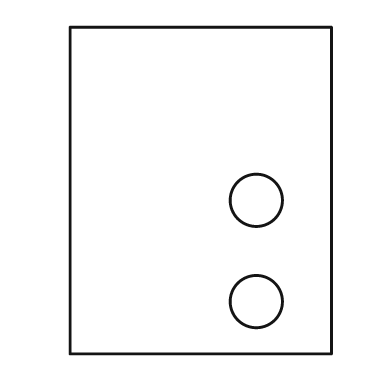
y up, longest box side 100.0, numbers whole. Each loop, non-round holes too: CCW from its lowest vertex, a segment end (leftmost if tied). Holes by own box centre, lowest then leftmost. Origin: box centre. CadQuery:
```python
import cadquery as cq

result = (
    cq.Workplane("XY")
    .moveTo(-40.0, -50.0)
    .lineTo(40.0, -50.0)
    .lineTo(40.0, 50.0)
    .lineTo(-40.0, 50.0)
    .close()
    .moveTo(17.0, -34.0)
    .circle(8.0)
    .moveTo(17.0, -3.0)
    .circle(8.0)
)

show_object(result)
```